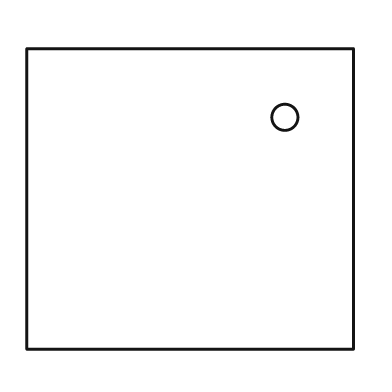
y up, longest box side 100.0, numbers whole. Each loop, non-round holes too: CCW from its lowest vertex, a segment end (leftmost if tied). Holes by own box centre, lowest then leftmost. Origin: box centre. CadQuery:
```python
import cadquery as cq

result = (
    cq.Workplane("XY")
    .moveTo(-50.0, -46.0)
    .lineTo(50.0, -46.0)
    .lineTo(50.0, 46.0)
    .lineTo(-50.0, 46.0)
    .close()
    .moveTo(29.0, 25.0)
    .circle(4.0)
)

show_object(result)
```